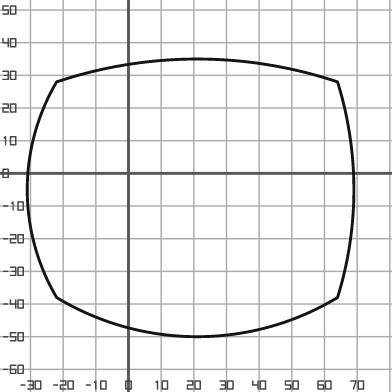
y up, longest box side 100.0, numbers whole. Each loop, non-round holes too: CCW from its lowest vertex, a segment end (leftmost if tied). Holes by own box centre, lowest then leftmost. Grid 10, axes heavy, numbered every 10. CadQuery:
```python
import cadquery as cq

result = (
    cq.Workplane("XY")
    .moveTo(-22.0, -38.0)
    .threePointArc((21.0, -50.0), (64.0, -38.0))
    .threePointArc((69.0, -5.0), (64.0, 28.0))
    .threePointArc((21.0, 35.0), (-22.0, 28.0))
    .threePointArc((-31.0, -5.0), (-22.0, -38.0))
    .close()
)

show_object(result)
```